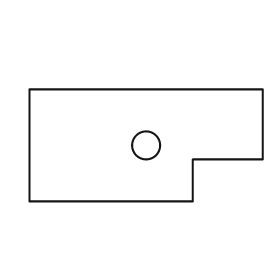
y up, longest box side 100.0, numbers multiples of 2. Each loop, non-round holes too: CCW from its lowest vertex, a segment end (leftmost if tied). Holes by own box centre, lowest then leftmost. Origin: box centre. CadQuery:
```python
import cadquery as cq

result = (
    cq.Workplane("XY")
    .moveTo(-50.0, -24.0)
    .lineTo(20.0, -24.0)
    .lineTo(20.0, -6.0)
    .lineTo(50.0, -6.0)
    .lineTo(50.0, 24.0)
    .lineTo(-50.0, 24.0)
    .close()
    .moveTo(0.0, 0.0)
    .circle(6.0)
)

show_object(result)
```